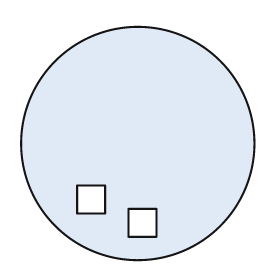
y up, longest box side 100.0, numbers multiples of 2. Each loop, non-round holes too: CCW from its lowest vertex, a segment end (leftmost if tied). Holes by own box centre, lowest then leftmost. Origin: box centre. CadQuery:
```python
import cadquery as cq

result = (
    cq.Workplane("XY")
    .moveTo(0.0, 0.0)
    .circle(50.0)
    .moveTo(-4.0, -40.0)
    .lineTo(8.0, -40.0)
    .lineTo(8.0, -28.0)
    .lineTo(-4.0, -28.0)
    .close()
    .moveTo(-26.0, -30.0)
    .lineTo(-14.0, -30.0)
    .lineTo(-14.0, -18.0)
    .lineTo(-26.0, -18.0)
    .close()
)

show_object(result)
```